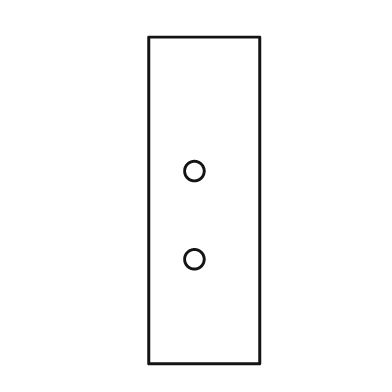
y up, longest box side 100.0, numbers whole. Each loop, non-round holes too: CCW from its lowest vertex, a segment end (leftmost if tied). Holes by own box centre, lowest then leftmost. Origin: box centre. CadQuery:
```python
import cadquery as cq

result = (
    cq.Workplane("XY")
    .moveTo(-17.0, -50.0)
    .lineTo(17.0, -50.0)
    .lineTo(17.0, 50.0)
    .lineTo(-17.0, 50.0)
    .close()
    .moveTo(-3.0, -18.0)
    .circle(3.0)
    .moveTo(-3.0, 9.0)
    .circle(3.0)
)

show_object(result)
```